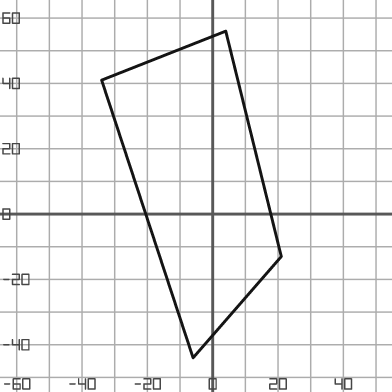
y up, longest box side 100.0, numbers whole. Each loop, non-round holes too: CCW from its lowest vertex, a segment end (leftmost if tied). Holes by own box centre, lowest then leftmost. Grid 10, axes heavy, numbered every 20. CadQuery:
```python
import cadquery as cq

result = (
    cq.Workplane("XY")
    .moveTo(-6.0, -44.0)
    .lineTo(21.0, -13.0)
    .lineTo(4.0, 56.0)
    .lineTo(-34.0, 41.0)
    .close()
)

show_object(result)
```